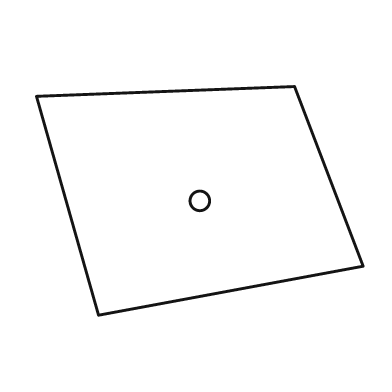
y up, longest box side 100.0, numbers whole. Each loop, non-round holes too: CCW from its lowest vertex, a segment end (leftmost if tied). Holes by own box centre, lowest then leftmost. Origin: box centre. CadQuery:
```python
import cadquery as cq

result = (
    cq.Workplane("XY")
    .moveTo(-31.0, -35.0)
    .lineTo(50.0, -20.0)
    .lineTo(29.0, 35.0)
    .lineTo(-50.0, 32.0)
    .close()
    .moveTo(0.0, 0.0)
    .circle(3.0)
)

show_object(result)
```